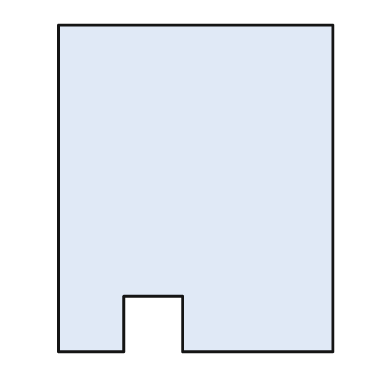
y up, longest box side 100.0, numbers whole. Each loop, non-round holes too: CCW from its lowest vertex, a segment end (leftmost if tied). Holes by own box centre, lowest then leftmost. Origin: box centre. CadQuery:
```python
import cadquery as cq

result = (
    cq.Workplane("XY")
    .moveTo(-42.0, -50.0)
    .lineTo(-22.0, -50.0)
    .lineTo(-22.0, -33.0)
    .lineTo(-4.0, -33.0)
    .lineTo(-4.0, -50.0)
    .lineTo(42.0, -50.0)
    .lineTo(42.0, 50.0)
    .lineTo(-42.0, 50.0)
    .close()
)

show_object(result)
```